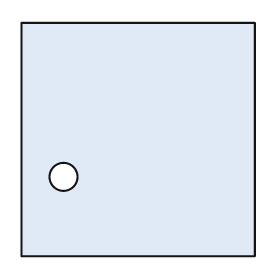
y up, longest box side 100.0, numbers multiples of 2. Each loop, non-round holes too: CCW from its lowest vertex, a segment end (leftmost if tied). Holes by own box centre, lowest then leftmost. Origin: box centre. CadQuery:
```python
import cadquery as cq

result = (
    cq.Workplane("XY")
    .moveTo(-50.0, -50.0)
    .lineTo(50.0, -50.0)
    .lineTo(50.0, 50.0)
    .lineTo(-50.0, 50.0)
    .close()
    .moveTo(-32.0, -16.0)
    .circle(6.0)
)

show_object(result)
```